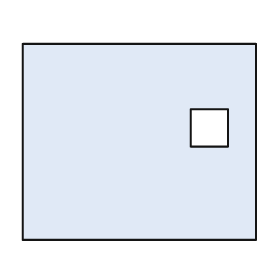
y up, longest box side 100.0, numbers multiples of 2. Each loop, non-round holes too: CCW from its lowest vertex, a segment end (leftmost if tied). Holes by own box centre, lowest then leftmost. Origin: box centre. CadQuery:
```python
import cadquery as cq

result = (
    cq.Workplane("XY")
    .moveTo(-50.0, -42.0)
    .lineTo(50.0, -42.0)
    .lineTo(50.0, 42.0)
    .lineTo(-50.0, 42.0)
    .close()
    .moveTo(22.0, -2.0)
    .lineTo(38.0, -2.0)
    .lineTo(38.0, 14.0)
    .lineTo(22.0, 14.0)
    .close()
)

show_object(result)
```